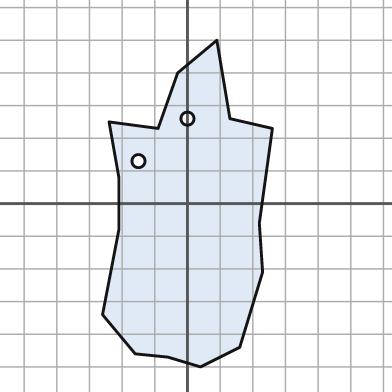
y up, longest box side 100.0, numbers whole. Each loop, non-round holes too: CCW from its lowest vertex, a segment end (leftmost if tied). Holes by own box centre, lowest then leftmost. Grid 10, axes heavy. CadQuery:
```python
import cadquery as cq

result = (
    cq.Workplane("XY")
    .moveTo(4.0, -50.0)
    .lineTo(16.0, -44.0)
    .lineTo(23.0, -21.0)
    .lineTo(22.0, -6.0)
    .lineTo(26.0, 23.0)
    .lineTo(13.0, 26.0)
    .lineTo(9.0, 50.0)
    .lineTo(-3.0, 40.0)
    .lineTo(-9.0, 23.0)
    .lineTo(-24.0, 25.0)
    .lineTo(-21.0, 8.0)
    .lineTo(-21.0, -8.0)
    .lineTo(-26.0, -34.0)
    .lineTo(-16.0, -46.0)
    .lineTo(-6.0, -47.0)
    .close()
    .moveTo(-15.0, 13.0)
    .circle(2.0)
    .moveTo(0.0, 26.0)
    .circle(2.0)
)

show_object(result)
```